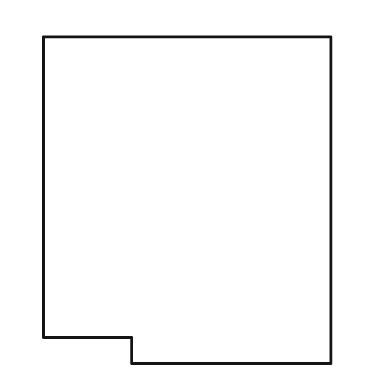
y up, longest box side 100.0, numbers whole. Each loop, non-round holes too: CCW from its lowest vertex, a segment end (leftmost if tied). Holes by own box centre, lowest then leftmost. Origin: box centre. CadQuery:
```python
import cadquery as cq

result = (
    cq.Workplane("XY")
    .moveTo(-17.0, -50.0)
    .lineTo(44.0, -50.0)
    .lineTo(44.0, 50.0)
    .lineTo(-44.0, 50.0)
    .lineTo(-44.0, -42.0)
    .lineTo(-17.0, -42.0)
    .close()
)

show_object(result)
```